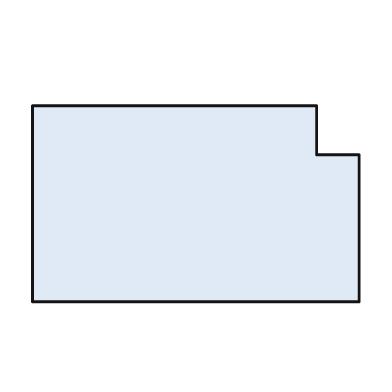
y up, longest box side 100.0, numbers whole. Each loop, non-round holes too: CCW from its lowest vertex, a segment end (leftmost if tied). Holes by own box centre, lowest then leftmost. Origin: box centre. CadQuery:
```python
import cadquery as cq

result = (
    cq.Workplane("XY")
    .moveTo(-50.0, -30.0)
    .lineTo(50.0, -30.0)
    .lineTo(50.0, 15.0)
    .lineTo(37.0, 15.0)
    .lineTo(37.0, 30.0)
    .lineTo(-50.0, 30.0)
    .close()
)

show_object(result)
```